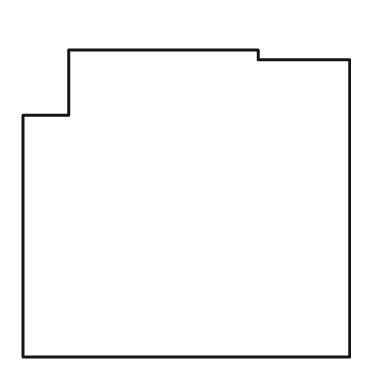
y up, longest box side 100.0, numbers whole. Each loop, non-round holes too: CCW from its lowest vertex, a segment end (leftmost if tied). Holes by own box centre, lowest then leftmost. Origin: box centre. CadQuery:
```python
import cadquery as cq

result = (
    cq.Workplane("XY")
    .moveTo(-50.0, -47.0)
    .lineTo(50.0, -47.0)
    .lineTo(50.0, 44.0)
    .lineTo(22.0, 44.0)
    .lineTo(22.0, 47.0)
    .lineTo(-36.0, 47.0)
    .lineTo(-36.0, 27.0)
    .lineTo(-50.0, 27.0)
    .close()
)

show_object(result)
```